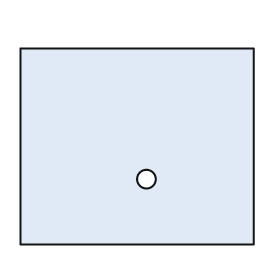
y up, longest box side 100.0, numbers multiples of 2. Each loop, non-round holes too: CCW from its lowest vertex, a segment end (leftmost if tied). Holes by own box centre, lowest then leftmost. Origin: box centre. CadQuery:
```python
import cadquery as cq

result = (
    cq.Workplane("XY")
    .moveTo(-50.0, -42.0)
    .lineTo(50.0, -42.0)
    .lineTo(50.0, 42.0)
    .lineTo(-50.0, 42.0)
    .close()
    .moveTo(4.0, -14.0)
    .circle(4.0)
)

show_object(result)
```